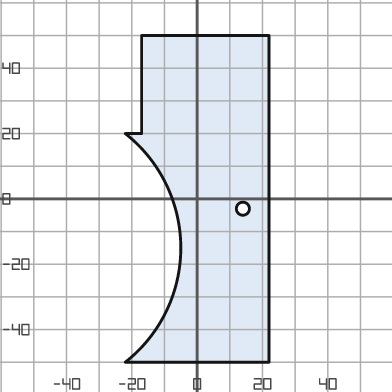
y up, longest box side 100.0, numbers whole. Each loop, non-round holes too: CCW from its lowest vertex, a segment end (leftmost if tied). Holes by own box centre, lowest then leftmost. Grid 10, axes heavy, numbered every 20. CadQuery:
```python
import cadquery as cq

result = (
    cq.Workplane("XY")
    .moveTo(-22.0, -50.0)
    .lineTo(22.0, -50.0)
    .lineTo(22.0, 50.0)
    .lineTo(-17.0, 50.0)
    .lineTo(-17.0, 20.0)
    .lineTo(-22.0, 20.0)
    .threePointArc((-5.0, -15.0), (-22.0, -50.0))
    .close()
    .moveTo(14.0, -3.0)
    .circle(2.0)
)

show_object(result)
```